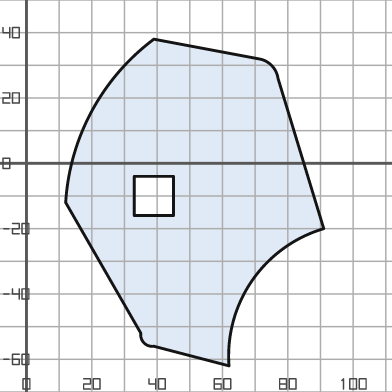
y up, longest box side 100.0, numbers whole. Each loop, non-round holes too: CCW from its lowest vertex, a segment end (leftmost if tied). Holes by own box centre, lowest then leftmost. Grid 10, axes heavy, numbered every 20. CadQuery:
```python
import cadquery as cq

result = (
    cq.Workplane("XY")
    .moveTo(62.0, -62.0)
    .threePointArc((69.0, -36.0), (91.0, -20.0))
    .lineTo(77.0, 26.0)
    .threePointArc((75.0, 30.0), (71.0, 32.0))
    .lineTo(39.0, 38.0)
    .threePointArc((20.0, 16.0), (12.0, -12.0))
    .lineTo(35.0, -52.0)
    .threePointArc((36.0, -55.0), (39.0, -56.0))
    .close()
    .moveTo(33.0, -16.0)
    .lineTo(45.0, -16.0)
    .lineTo(45.0, -4.0)
    .lineTo(33.0, -4.0)
    .close()
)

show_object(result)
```